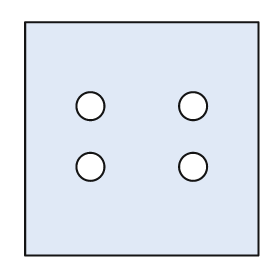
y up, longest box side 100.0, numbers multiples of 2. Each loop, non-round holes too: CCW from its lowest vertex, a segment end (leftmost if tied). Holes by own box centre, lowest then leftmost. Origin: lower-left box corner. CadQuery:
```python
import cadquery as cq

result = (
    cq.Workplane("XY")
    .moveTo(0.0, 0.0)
    .lineTo(100.0, 0.0)
    .lineTo(100.0, 100.0)
    .lineTo(0.0, 100.0)
    .close()
    .moveTo(28.0, 38.0)
    .circle(6.0)
    .moveTo(72.0, 38.0)
    .circle(6.0)
    .moveTo(28.0, 64.0)
    .circle(6.0)
    .moveTo(72.0, 64.0)
    .circle(6.0)
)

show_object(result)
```